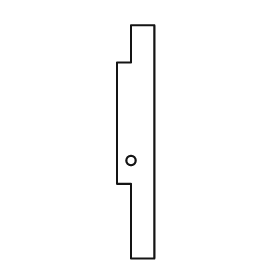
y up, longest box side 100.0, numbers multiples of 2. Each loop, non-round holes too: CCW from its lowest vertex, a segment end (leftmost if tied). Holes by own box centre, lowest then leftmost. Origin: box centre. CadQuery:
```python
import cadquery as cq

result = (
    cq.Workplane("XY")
    .moveTo(-2.0, -50.0)
    .lineTo(8.0, -50.0)
    .lineTo(8.0, 50.0)
    .lineTo(-2.0, 50.0)
    .lineTo(-2.0, 34.0)
    .lineTo(-8.0, 34.0)
    .lineTo(-8.0, -18.0)
    .lineTo(-2.0, -18.0)
    .close()
    .moveTo(-2.0, -8.0)
    .circle(2.0)
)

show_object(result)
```